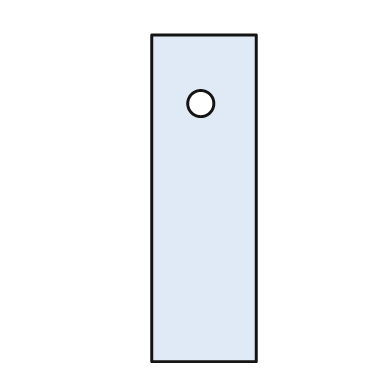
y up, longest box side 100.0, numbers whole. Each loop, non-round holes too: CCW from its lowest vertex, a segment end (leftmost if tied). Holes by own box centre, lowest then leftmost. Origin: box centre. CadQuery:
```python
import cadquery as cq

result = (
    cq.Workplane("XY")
    .moveTo(-16.0, -50.0)
    .lineTo(16.0, -50.0)
    .lineTo(16.0, 50.0)
    .lineTo(-16.0, 50.0)
    .close()
    .moveTo(-1.0, 29.0)
    .circle(4.0)
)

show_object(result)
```